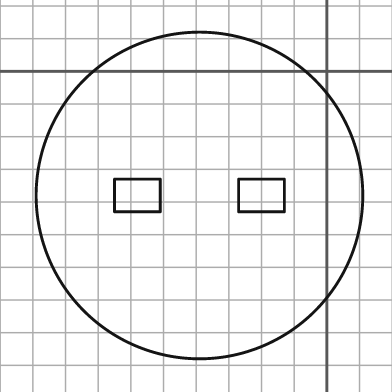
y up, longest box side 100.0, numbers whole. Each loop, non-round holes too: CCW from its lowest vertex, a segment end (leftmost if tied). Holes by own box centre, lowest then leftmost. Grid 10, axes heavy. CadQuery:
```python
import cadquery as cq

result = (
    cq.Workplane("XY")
    .moveTo(-39.0, -38.0)
    .circle(50.0)
    .moveTo(-65.0, -43.0)
    .lineTo(-51.0, -43.0)
    .lineTo(-51.0, -33.0)
    .lineTo(-65.0, -33.0)
    .close()
    .moveTo(-27.0, -43.0)
    .lineTo(-13.0, -43.0)
    .lineTo(-13.0, -33.0)
    .lineTo(-27.0, -33.0)
    .close()
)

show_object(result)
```